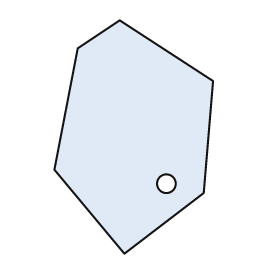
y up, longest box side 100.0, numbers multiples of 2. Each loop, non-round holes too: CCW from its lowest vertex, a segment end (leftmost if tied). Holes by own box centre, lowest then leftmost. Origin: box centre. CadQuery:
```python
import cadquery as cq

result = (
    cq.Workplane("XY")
    .moveTo(-4.0, -50.0)
    .lineTo(30.0, -24.0)
    .lineTo(34.0, 24.0)
    .lineTo(-6.0, 50.0)
    .lineTo(-24.0, 38.0)
    .lineTo(-34.0, -14.0)
    .close()
    .moveTo(14.0, -20.0)
    .circle(4.0)
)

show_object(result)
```